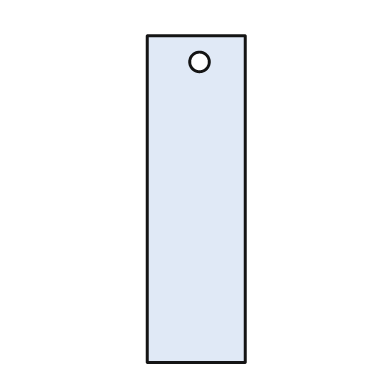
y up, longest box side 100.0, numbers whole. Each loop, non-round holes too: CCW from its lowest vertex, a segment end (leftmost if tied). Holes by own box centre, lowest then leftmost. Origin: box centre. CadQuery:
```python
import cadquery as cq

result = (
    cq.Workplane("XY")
    .moveTo(-15.0, -50.0)
    .lineTo(15.0, -50.0)
    .lineTo(15.0, 50.0)
    .lineTo(-15.0, 50.0)
    .close()
    .moveTo(1.0, 42.0)
    .circle(3.0)
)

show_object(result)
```